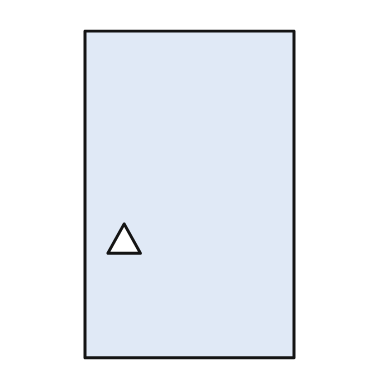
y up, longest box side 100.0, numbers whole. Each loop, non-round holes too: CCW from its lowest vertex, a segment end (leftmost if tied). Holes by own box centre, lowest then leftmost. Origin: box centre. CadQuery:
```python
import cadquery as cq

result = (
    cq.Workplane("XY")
    .moveTo(-32.0, -50.0)
    .lineTo(32.0, -50.0)
    .lineTo(32.0, 50.0)
    .lineTo(-32.0, 50.0)
    .close()
    .moveTo(-25.0, -18.0)
    .lineTo(-15.0, -18.0)
    .lineTo(-20.0, -9.0)
    .close()
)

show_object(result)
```